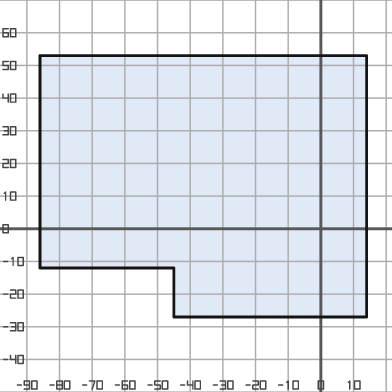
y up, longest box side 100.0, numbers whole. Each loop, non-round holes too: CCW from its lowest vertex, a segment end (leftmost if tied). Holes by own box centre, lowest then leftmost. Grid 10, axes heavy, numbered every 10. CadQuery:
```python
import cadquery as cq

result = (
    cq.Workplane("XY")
    .moveTo(-45.0, -27.0)
    .lineTo(14.0, -27.0)
    .lineTo(14.0, 53.0)
    .lineTo(-86.0, 53.0)
    .lineTo(-86.0, -12.0)
    .lineTo(-45.0, -12.0)
    .close()
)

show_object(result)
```